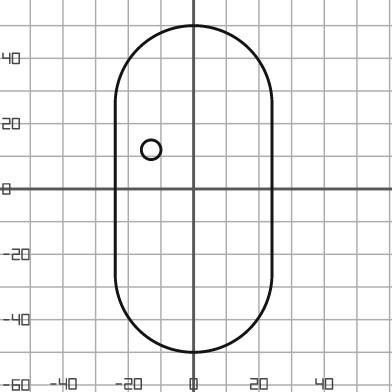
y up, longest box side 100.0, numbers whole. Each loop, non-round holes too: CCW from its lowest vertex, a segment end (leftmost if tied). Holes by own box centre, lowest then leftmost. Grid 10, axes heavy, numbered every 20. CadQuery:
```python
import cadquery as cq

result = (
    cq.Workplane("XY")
    .moveTo(-24.0, -26.0)
    .threePointArc((0.0, -50.0), (24.0, -26.0))
    .lineTo(24.0, 26.0)
    .threePointArc((0.0, 50.0), (-24.0, 26.0))
    .close()
    .moveTo(-13.0, 12.0)
    .circle(3.0)
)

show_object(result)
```